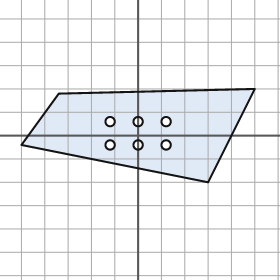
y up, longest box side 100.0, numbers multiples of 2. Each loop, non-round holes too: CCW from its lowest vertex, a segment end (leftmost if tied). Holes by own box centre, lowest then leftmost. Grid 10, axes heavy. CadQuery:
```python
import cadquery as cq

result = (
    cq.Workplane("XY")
    .moveTo(30.0, -20.0)
    .lineTo(50.0, 20.0)
    .lineTo(-34.0, 18.0)
    .lineTo(-50.0, -4.0)
    .close()
    .moveTo(-12.0, -4.0)
    .circle(2.0)
    .moveTo(0.0, -4.0)
    .circle(2.0)
    .moveTo(12.0, -4.0)
    .circle(2.0)
    .moveTo(-12.0, 6.0)
    .circle(2.0)
    .moveTo(0.0, 6.0)
    .circle(2.0)
    .moveTo(12.0, 6.0)
    .circle(2.0)
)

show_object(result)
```